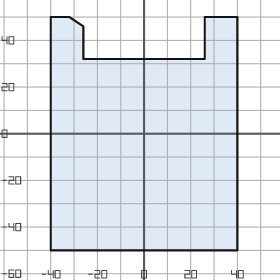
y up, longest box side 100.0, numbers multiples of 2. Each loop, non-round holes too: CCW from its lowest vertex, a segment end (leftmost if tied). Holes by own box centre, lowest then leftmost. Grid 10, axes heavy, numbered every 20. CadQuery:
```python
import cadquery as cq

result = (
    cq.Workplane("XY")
    .moveTo(-40.0, -50.0)
    .lineTo(40.0, -50.0)
    .lineTo(40.0, 50.0)
    .lineTo(26.0, 50.0)
    .lineTo(26.0, 32.0)
    .lineTo(-26.0, 32.0)
    .lineTo(-26.0, 46.0)
    .lineTo(-32.0, 50.0)
    .lineTo(-40.0, 50.0)
    .close()
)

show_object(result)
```